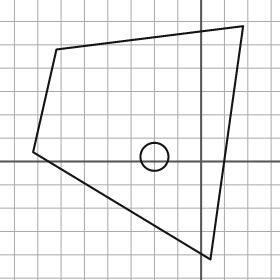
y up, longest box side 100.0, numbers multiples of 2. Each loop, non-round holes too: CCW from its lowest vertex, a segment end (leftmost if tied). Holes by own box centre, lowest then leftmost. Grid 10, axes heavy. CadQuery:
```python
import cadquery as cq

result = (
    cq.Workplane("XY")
    .moveTo(4.0, -42.0)
    .lineTo(18.0, 58.0)
    .lineTo(-62.0, 48.0)
    .lineTo(-72.0, 4.0)
    .close()
    .moveTo(-20.0, 2.0)
    .circle(6.0)
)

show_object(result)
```